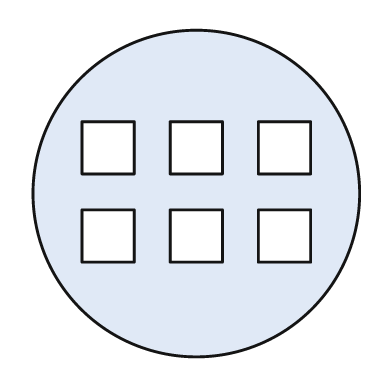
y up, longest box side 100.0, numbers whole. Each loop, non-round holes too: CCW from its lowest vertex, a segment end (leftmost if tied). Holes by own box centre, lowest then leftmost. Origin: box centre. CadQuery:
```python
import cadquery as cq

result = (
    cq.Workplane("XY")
    .moveTo(0.0, 0.0)
    .circle(50.0)
    .moveTo(-35.0, -21.0)
    .lineTo(-19.0, -21.0)
    .lineTo(-19.0, -5.0)
    .lineTo(-35.0, -5.0)
    .close()
    .moveTo(-8.0, -21.0)
    .lineTo(8.0, -21.0)
    .lineTo(8.0, -5.0)
    .lineTo(-8.0, -5.0)
    .close()
    .moveTo(19.0, -21.0)
    .lineTo(35.0, -21.0)
    .lineTo(35.0, -5.0)
    .lineTo(19.0, -5.0)
    .close()
    .moveTo(-35.0, 6.0)
    .lineTo(-19.0, 6.0)
    .lineTo(-19.0, 22.0)
    .lineTo(-35.0, 22.0)
    .close()
    .moveTo(-8.0, 6.0)
    .lineTo(8.0, 6.0)
    .lineTo(8.0, 22.0)
    .lineTo(-8.0, 22.0)
    .close()
    .moveTo(19.0, 6.0)
    .lineTo(35.0, 6.0)
    .lineTo(35.0, 22.0)
    .lineTo(19.0, 22.0)
    .close()
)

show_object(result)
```